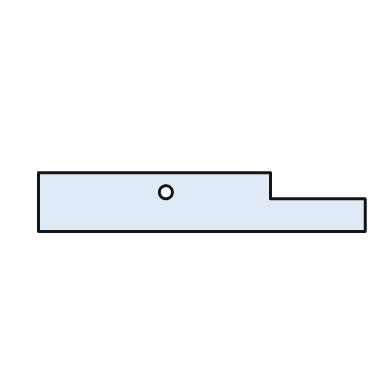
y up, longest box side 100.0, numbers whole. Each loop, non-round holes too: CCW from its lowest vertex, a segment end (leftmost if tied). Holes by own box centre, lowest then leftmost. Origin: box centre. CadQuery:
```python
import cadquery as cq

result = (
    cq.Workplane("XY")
    .moveTo(-50.0, -9.0)
    .lineTo(50.0, -9.0)
    .lineTo(50.0, 1.0)
    .lineTo(21.0, 1.0)
    .lineTo(21.0, 9.0)
    .lineTo(-50.0, 9.0)
    .close()
    .moveTo(-11.0, 3.0)
    .circle(2.0)
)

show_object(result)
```